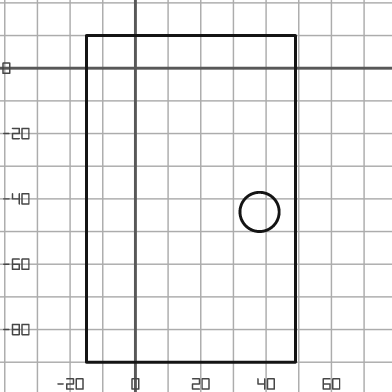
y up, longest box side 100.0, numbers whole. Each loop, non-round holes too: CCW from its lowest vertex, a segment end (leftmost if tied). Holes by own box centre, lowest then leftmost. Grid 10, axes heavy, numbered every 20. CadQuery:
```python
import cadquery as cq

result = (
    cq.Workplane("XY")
    .moveTo(-15.0, -90.0)
    .lineTo(49.0, -90.0)
    .lineTo(49.0, 10.0)
    .lineTo(-15.0, 10.0)
    .close()
    .moveTo(38.0, -44.0)
    .circle(6.0)
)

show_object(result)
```